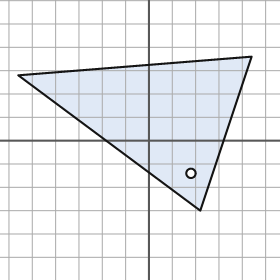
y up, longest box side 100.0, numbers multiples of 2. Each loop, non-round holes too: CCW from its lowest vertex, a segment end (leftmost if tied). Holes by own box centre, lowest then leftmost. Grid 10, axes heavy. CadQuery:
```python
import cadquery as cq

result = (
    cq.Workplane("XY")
    .moveTo(22.0, -30.0)
    .lineTo(44.0, 36.0)
    .lineTo(-56.0, 28.0)
    .close()
    .moveTo(18.0, -14.0)
    .circle(2.0)
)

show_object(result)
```